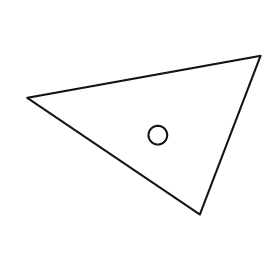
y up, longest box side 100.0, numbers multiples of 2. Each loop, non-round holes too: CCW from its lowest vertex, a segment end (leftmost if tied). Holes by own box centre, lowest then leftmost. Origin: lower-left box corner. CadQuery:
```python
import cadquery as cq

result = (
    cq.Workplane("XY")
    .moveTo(74.0, 0.0)
    .lineTo(100.0, 68.0)
    .lineTo(0.0, 50.0)
    .close()
    .moveTo(56.0, 34.0)
    .circle(4.0)
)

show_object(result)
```